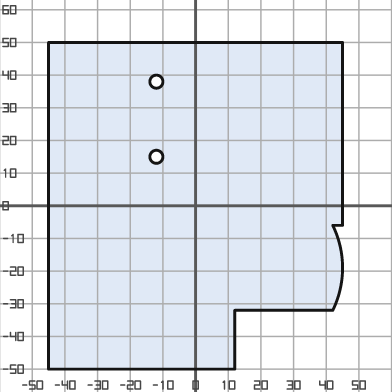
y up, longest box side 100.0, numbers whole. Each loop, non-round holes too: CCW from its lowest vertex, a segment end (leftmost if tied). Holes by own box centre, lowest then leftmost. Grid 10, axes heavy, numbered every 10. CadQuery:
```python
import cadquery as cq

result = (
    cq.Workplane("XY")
    .moveTo(-45.0, -50.0)
    .lineTo(12.0, -50.0)
    .lineTo(12.0, -32.0)
    .lineTo(42.0, -32.0)
    .threePointArc((45.0, -19.0), (42.0, -6.0))
    .lineTo(45.0, -6.0)
    .lineTo(45.0, 50.0)
    .lineTo(-45.0, 50.0)
    .close()
    .moveTo(-12.0, 15.0)
    .circle(2.0)
    .moveTo(-12.0, 38.0)
    .circle(2.0)
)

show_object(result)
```